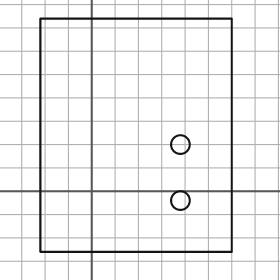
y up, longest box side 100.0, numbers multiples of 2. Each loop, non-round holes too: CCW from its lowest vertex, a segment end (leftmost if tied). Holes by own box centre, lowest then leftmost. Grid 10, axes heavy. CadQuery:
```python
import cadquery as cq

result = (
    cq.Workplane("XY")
    .moveTo(-22.0, -26.0)
    .lineTo(60.0, -26.0)
    .lineTo(60.0, 74.0)
    .lineTo(-22.0, 74.0)
    .close()
    .moveTo(38.0, -4.0)
    .circle(4.0)
    .moveTo(38.0, 20.0)
    .circle(4.0)
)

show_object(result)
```